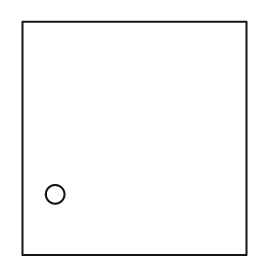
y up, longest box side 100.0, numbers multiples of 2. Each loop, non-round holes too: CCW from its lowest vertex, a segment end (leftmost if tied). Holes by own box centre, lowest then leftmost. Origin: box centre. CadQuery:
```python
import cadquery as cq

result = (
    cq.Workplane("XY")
    .moveTo(-48.0, -50.0)
    .lineTo(48.0, -50.0)
    .lineTo(48.0, 50.0)
    .lineTo(-48.0, 50.0)
    .close()
    .moveTo(-34.0, -24.0)
    .circle(4.0)
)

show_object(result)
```